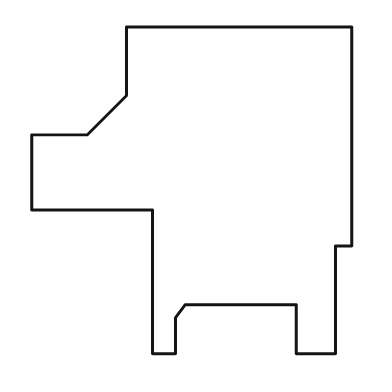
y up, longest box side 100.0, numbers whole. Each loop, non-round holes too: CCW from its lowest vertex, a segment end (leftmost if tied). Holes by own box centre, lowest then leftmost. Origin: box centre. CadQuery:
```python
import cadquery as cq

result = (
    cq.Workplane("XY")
    .moveTo(-12.0, -50.0)
    .lineTo(-5.0, -50.0)
    .lineTo(-5.0, -39.0)
    .lineTo(-2.0, -35.0)
    .lineTo(32.0, -35.0)
    .lineTo(32.0, -50.0)
    .lineTo(44.0, -50.0)
    .lineTo(44.0, -17.0)
    .lineTo(49.0, -17.0)
    .lineTo(49.0, 50.0)
    .lineTo(-20.0, 50.0)
    .lineTo(-20.0, 29.0)
    .lineTo(-32.0, 17.0)
    .lineTo(-49.0, 17.0)
    .lineTo(-49.0, -6.0)
    .lineTo(-12.0, -6.0)
    .close()
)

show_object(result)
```